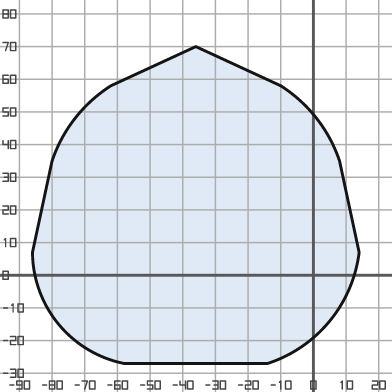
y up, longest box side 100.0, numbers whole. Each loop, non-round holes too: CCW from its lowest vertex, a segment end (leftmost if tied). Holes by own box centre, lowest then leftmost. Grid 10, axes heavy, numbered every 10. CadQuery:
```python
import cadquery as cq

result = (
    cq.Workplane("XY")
    .moveTo(-58.0, -27.0)
    .lineTo(-14.0, -27.0)
    .threePointArc((5.0, -14.0), (14.0, 7.0))
    .lineTo(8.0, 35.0)
    .threePointArc((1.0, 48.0), (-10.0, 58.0))
    .lineTo(-36.0, 70.0)
    .lineTo(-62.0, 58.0)
    .threePointArc((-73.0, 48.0), (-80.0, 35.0))
    .lineTo(-86.0, 7.0)
    .threePointArc((-78.0, -15.0), (-58.0, -27.0))
    .close()
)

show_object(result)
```